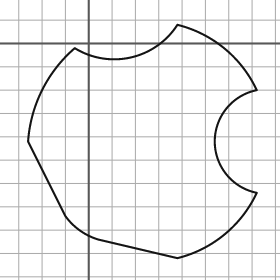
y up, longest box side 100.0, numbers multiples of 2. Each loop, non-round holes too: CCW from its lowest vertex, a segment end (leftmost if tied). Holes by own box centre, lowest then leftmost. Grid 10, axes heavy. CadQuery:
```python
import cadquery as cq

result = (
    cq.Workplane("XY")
    .moveTo(38.0, -92.0)
    .threePointArc((58.0, -82.0), (72.0, -64.0))
    .threePointArc((54.0, -42.0), (72.0, -20.0))
    .threePointArc((58.0, -2.0), (38.0, 8.0))
    .threePointArc((18.0, -6.0), (-6.0, -2.0))
    .threePointArc((-20.0, -20.0), (-26.0, -42.0))
    .lineTo(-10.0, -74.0)
    .threePointArc((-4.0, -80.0), (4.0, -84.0))
    .close()
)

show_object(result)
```